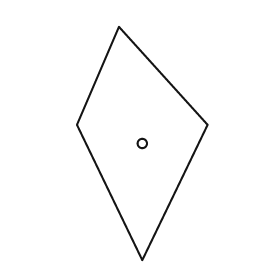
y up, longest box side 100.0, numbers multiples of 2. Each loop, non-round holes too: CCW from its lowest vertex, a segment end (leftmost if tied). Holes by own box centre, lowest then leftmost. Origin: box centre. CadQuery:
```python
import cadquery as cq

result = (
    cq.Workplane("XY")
    .moveTo(0.0, -50.0)
    .lineTo(28.0, 8.0)
    .lineTo(-10.0, 50.0)
    .lineTo(-28.0, 8.0)
    .close()
    .moveTo(0.0, 0.0)
    .circle(2.0)
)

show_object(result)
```